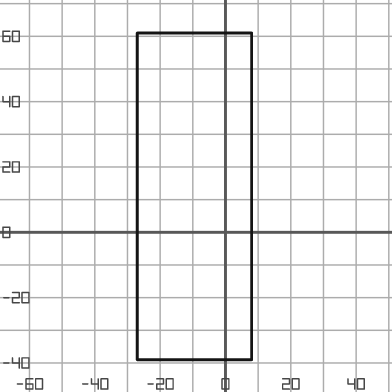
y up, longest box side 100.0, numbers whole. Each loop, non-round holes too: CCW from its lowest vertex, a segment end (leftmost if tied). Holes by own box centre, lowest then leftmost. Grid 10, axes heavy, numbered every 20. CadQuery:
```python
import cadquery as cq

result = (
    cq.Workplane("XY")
    .moveTo(-27.0, -39.0)
    .lineTo(8.0, -39.0)
    .lineTo(8.0, 61.0)
    .lineTo(-27.0, 61.0)
    .close()
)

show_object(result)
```